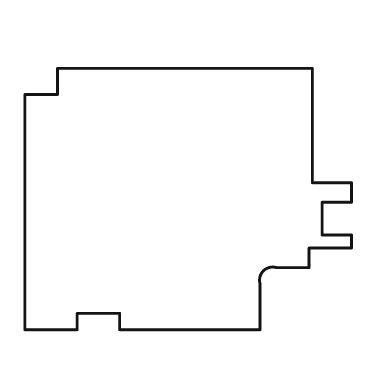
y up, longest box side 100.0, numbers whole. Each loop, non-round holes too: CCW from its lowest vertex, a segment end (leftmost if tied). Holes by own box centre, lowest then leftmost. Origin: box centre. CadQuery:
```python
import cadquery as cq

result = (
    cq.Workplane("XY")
    .moveTo(-50.0, -40.0)
    .lineTo(-34.0, -40.0)
    .lineTo(-34.0, -35.0)
    .lineTo(-21.0, -35.0)
    .lineTo(-21.0, -40.0)
    .lineTo(22.0, -40.0)
    .lineTo(22.0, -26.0)
    .threePointArc((23.0, -22.0), (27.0, -21.0))
    .lineTo(37.0, -21.0)
    .lineTo(37.0, -15.0)
    .lineTo(50.0, -15.0)
    .lineTo(50.0, -11.0)
    .lineTo(41.0, -11.0)
    .lineTo(41.0, -1.0)
    .lineTo(50.0, -1.0)
    .lineTo(50.0, 5.0)
    .lineTo(38.0, 5.0)
    .lineTo(38.0, 40.0)
    .lineTo(-40.0, 40.0)
    .lineTo(-40.0, 32.0)
    .lineTo(-50.0, 32.0)
    .close()
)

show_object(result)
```